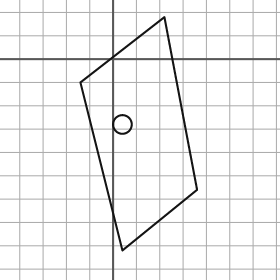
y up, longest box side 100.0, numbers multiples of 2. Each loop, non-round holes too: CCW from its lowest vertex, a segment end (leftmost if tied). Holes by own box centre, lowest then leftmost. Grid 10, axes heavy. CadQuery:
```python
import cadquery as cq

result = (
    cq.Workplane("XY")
    .moveTo(4.0, -82.0)
    .lineTo(36.0, -56.0)
    .lineTo(22.0, 18.0)
    .lineTo(-14.0, -10.0)
    .close()
    .moveTo(4.0, -28.0)
    .circle(4.0)
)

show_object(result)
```